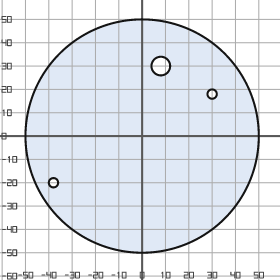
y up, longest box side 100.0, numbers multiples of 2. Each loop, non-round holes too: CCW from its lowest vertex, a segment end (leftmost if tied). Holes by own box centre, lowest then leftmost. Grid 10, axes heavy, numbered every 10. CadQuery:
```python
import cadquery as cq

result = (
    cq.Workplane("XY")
    .moveTo(0.0, 0.0)
    .circle(50.0)
    .moveTo(-38.0, -20.0)
    .circle(2.0)
    .moveTo(30.0, 18.0)
    .circle(2.0)
    .moveTo(8.0, 30.0)
    .circle(4.0)
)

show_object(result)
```